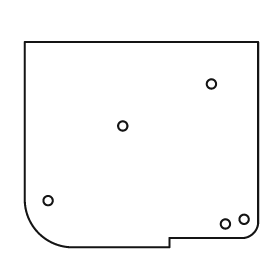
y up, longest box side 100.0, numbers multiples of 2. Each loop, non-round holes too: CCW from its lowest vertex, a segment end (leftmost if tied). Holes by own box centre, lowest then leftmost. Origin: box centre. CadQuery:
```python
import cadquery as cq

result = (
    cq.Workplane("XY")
    .moveTo(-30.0, -44.0)
    .lineTo(12.0, -44.0)
    .lineTo(12.0, -40.0)
    .lineTo(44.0, -40.0)
    .threePointArc((48.0, -38.0), (50.0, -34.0))
    .lineTo(50.0, 44.0)
    .lineTo(-50.0, 44.0)
    .lineTo(-50.0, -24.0)
    .threePointArc((-44.0, -38.0), (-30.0, -44.0))
    .close()
    .moveTo(36.0, -34.0)
    .circle(2.0)
    .moveTo(44.0, -32.0)
    .circle(2.0)
    .moveTo(-40.0, -24.0)
    .circle(2.0)
    .moveTo(-8.0, 8.0)
    .circle(2.0)
    .moveTo(30.0, 26.0)
    .circle(2.0)
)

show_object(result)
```